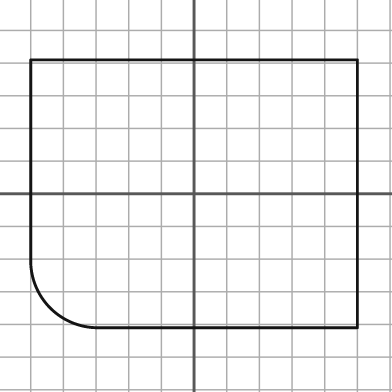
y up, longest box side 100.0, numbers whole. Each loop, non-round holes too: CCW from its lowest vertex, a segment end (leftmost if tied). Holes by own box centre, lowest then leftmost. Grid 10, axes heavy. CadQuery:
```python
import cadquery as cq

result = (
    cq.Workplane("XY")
    .moveTo(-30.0, -41.0)
    .lineTo(50.0, -41.0)
    .lineTo(50.0, 41.0)
    .lineTo(-50.0, 41.0)
    .lineTo(-50.0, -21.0)
    .threePointArc((-44.0, -35.0), (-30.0, -41.0))
    .close()
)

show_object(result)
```